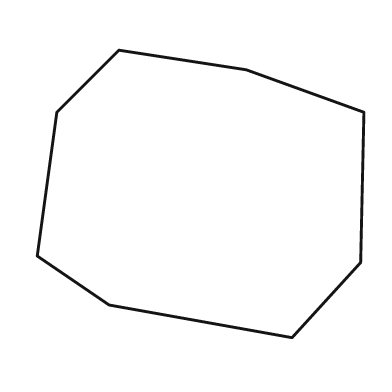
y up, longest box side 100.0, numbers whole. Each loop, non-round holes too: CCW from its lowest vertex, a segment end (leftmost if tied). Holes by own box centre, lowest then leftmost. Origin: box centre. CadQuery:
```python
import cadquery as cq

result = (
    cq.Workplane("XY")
    .moveTo(28.0, -44.0)
    .lineTo(49.0, -21.0)
    .lineTo(50.0, 25.0)
    .lineTo(14.0, 38.0)
    .lineTo(-25.0, 44.0)
    .lineTo(-44.0, 25.0)
    .lineTo(-50.0, -19.0)
    .lineTo(-28.0, -34.0)
    .close()
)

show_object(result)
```